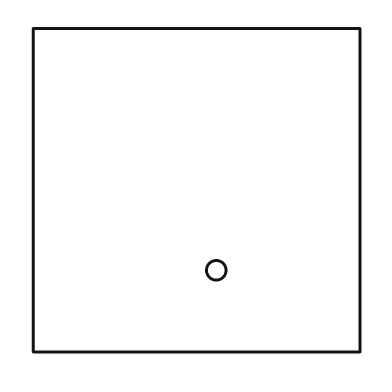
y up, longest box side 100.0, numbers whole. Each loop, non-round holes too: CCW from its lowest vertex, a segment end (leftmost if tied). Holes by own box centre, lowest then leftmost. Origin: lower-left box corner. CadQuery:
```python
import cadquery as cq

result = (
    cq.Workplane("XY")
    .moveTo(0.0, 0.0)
    .lineTo(100.0, 0.0)
    .lineTo(100.0, 99.0)
    .lineTo(0.0, 99.0)
    .close()
    .moveTo(56.0, 25.0)
    .circle(3.0)
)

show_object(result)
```